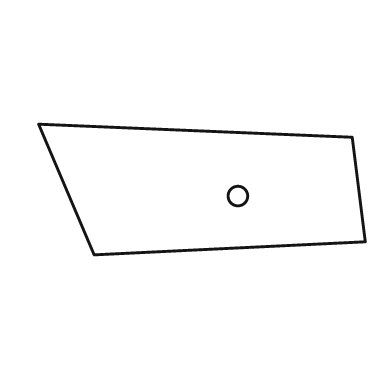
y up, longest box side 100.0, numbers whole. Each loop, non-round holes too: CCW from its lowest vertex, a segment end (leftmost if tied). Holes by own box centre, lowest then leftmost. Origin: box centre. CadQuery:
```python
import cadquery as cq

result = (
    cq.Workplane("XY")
    .moveTo(-33.0, -20.0)
    .lineTo(50.0, -16.0)
    .lineTo(46.0, 16.0)
    .lineTo(-50.0, 20.0)
    .close()
    .moveTo(11.0, -2.0)
    .circle(3.0)
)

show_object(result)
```